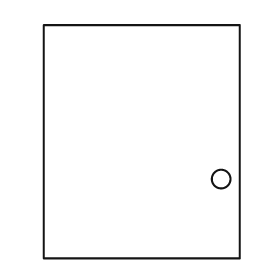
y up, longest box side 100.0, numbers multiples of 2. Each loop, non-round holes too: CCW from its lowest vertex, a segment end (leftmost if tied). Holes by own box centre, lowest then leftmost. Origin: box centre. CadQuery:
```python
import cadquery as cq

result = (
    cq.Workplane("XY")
    .moveTo(-42.0, -50.0)
    .lineTo(42.0, -50.0)
    .lineTo(42.0, 50.0)
    .lineTo(-42.0, 50.0)
    .close()
    .moveTo(34.0, -16.0)
    .circle(4.0)
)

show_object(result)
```